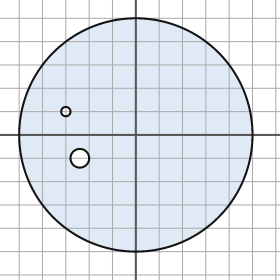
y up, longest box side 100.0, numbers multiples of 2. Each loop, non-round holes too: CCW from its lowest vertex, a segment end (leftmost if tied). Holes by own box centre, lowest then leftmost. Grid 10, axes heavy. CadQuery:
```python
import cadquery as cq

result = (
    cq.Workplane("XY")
    .moveTo(0.0, 0.0)
    .circle(50.0)
    .moveTo(-24.0, -10.0)
    .circle(4.0)
    .moveTo(-30.0, 10.0)
    .circle(2.0)
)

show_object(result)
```